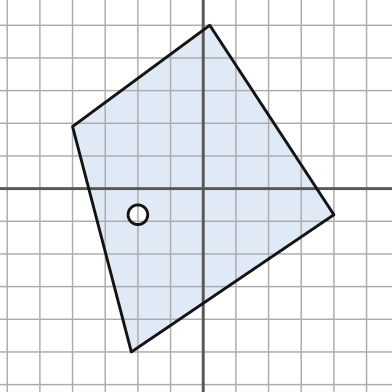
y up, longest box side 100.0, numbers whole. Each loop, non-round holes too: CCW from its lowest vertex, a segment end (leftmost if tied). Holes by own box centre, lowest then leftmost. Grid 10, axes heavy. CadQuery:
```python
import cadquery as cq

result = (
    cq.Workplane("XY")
    .moveTo(-22.0, -50.0)
    .lineTo(40.0, -8.0)
    .lineTo(2.0, 50.0)
    .lineTo(-40.0, 19.0)
    .close()
    .moveTo(-20.0, -8.0)
    .circle(3.0)
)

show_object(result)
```